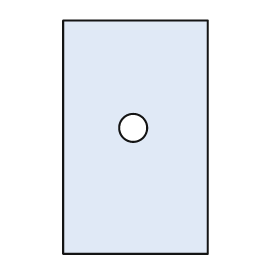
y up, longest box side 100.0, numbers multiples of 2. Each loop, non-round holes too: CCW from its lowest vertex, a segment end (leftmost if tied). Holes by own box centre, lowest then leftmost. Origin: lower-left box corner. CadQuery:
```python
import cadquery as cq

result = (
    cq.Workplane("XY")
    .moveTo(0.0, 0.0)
    .lineTo(62.0, 0.0)
    .lineTo(62.0, 100.0)
    .lineTo(0.0, 100.0)
    .close()
    .moveTo(30.0, 54.0)
    .circle(6.0)
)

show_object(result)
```